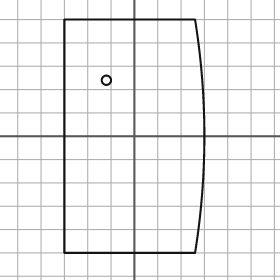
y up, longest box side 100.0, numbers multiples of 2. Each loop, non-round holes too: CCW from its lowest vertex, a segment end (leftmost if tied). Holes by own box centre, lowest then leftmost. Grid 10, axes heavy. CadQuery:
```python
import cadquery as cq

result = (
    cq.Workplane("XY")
    .moveTo(-30.0, -50.0)
    .lineTo(26.0, -50.0)
    .threePointArc((30.0, 0.0), (26.0, 50.0))
    .lineTo(-30.0, 50.0)
    .close()
    .moveTo(-12.0, 24.0)
    .circle(2.0)
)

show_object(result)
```